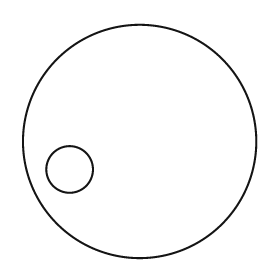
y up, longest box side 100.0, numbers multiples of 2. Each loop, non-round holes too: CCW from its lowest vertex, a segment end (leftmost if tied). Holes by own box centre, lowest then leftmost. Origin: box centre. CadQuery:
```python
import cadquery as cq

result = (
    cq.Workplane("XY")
    .moveTo(0.0, 0.0)
    .circle(50.0)
    .moveTo(-30.0, -12.0)
    .circle(10.0)
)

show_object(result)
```